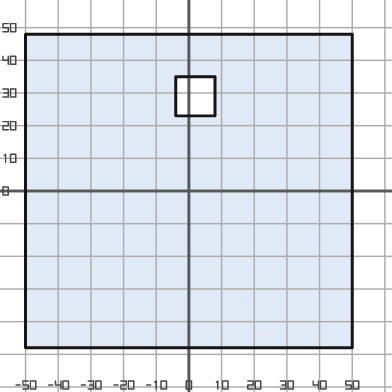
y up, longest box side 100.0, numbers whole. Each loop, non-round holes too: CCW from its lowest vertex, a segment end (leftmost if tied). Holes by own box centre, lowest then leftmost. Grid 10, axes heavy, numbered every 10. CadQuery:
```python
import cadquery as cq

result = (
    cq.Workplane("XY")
    .moveTo(-50.0, -48.0)
    .lineTo(50.0, -48.0)
    .lineTo(50.0, 48.0)
    .lineTo(-50.0, 48.0)
    .close()
    .moveTo(-4.0, 23.0)
    .lineTo(8.0, 23.0)
    .lineTo(8.0, 35.0)
    .lineTo(-4.0, 35.0)
    .close()
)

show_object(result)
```